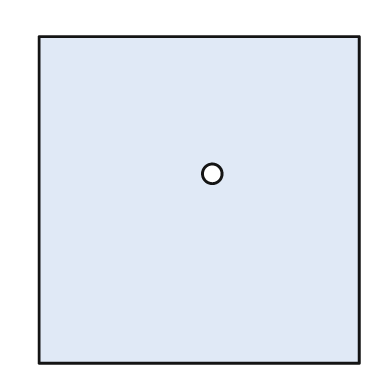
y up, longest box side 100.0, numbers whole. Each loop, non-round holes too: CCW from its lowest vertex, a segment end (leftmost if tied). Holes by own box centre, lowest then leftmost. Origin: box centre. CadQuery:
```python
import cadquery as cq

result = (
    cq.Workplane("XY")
    .moveTo(-49.0, -50.0)
    .lineTo(49.0, -50.0)
    .lineTo(49.0, 50.0)
    .lineTo(-49.0, 50.0)
    .close()
    .moveTo(4.0, 8.0)
    .circle(3.0)
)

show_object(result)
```